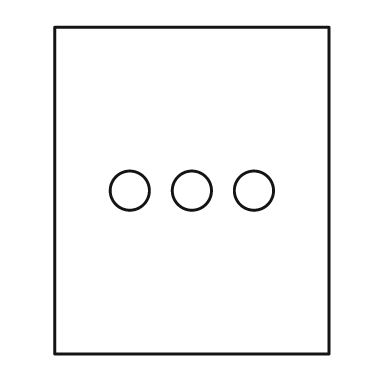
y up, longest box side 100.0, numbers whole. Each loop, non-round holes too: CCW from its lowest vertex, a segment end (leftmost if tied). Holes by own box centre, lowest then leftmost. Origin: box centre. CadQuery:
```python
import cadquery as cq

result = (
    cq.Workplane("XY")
    .moveTo(-42.0, -50.0)
    .lineTo(42.0, -50.0)
    .lineTo(42.0, 50.0)
    .lineTo(-42.0, 50.0)
    .close()
    .moveTo(-19.0, 0.0)
    .circle(6.0)
    .moveTo(0.0, 0.0)
    .circle(6.0)
    .moveTo(19.0, 0.0)
    .circle(6.0)
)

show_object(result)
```